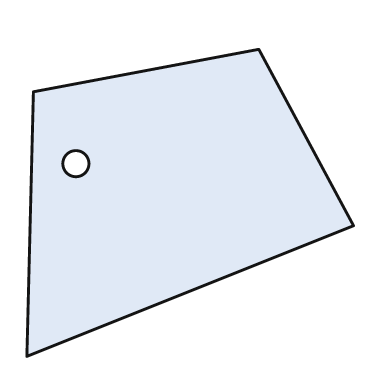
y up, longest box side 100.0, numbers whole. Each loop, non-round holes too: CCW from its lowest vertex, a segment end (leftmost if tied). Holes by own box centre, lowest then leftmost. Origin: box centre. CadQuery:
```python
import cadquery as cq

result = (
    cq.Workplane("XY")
    .moveTo(-50.0, -47.0)
    .lineTo(50.0, -7.0)
    .lineTo(21.0, 47.0)
    .lineTo(-48.0, 34.0)
    .close()
    .moveTo(-35.0, 12.0)
    .circle(4.0)
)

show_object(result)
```